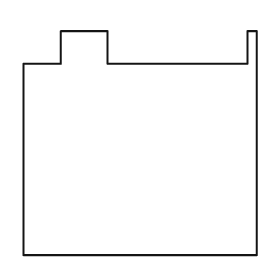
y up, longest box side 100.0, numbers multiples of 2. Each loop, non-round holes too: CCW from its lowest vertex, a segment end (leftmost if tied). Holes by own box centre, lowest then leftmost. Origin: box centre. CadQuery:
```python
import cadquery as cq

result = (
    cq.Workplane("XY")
    .moveTo(-50.0, -48.0)
    .lineTo(50.0, -48.0)
    .lineTo(50.0, 48.0)
    .lineTo(46.0, 48.0)
    .lineTo(46.0, 34.0)
    .lineTo(-14.0, 34.0)
    .lineTo(-14.0, 48.0)
    .lineTo(-34.0, 48.0)
    .lineTo(-34.0, 34.0)
    .lineTo(-50.0, 34.0)
    .close()
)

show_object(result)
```